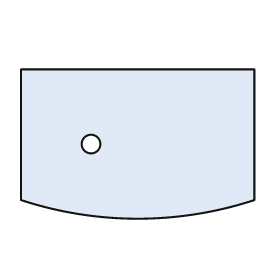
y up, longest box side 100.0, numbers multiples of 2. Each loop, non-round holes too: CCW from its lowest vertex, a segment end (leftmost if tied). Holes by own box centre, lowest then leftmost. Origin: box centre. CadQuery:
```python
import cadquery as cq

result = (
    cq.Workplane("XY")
    .moveTo(-50.0, -24.0)
    .threePointArc((0.0, -32.0), (50.0, -24.0))
    .lineTo(50.0, 32.0)
    .lineTo(-50.0, 32.0)
    .close()
    .moveTo(-20.0, 0.0)
    .circle(4.0)
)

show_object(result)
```